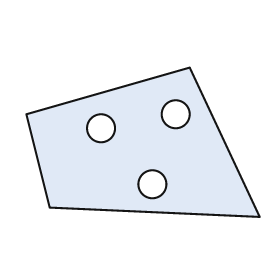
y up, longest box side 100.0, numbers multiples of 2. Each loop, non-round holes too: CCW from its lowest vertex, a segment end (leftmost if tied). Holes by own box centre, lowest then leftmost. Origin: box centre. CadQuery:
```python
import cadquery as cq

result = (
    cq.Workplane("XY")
    .moveTo(50.0, -32.0)
    .lineTo(20.0, 32.0)
    .lineTo(-50.0, 12.0)
    .lineTo(-40.0, -28.0)
    .close()
    .moveTo(4.0, -18.0)
    .circle(6.0)
    .moveTo(-18.0, 6.0)
    .circle(6.0)
    .moveTo(14.0, 12.0)
    .circle(6.0)
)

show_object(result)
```